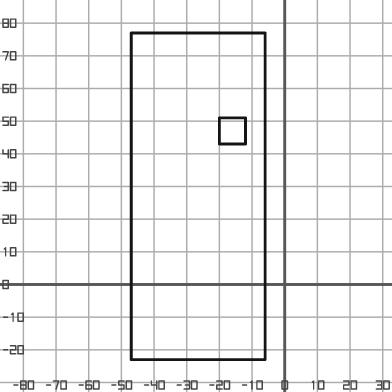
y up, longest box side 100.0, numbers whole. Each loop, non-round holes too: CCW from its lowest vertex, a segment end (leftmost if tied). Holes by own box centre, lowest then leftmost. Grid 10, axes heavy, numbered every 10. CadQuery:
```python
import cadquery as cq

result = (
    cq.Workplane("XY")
    .moveTo(-47.0, -23.0)
    .lineTo(-6.0, -23.0)
    .lineTo(-6.0, 77.0)
    .lineTo(-47.0, 77.0)
    .close()
    .moveTo(-20.0, 43.0)
    .lineTo(-12.0, 43.0)
    .lineTo(-12.0, 51.0)
    .lineTo(-20.0, 51.0)
    .close()
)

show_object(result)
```